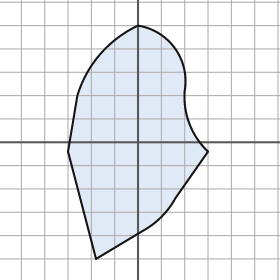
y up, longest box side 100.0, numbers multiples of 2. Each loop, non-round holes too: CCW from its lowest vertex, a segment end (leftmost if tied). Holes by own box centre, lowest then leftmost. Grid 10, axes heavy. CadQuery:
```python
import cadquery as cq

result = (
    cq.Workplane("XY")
    .moveTo(-18.0, -50.0)
    .lineTo(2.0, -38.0)
    .threePointArc((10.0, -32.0), (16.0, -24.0))
    .lineTo(30.0, -4.0)
    .threePointArc((22.0, 8.0), (20.0, 22.0))
    .threePointArc((16.0, 40.0), (0.0, 50.0))
    .threePointArc((-16.0, 38.0), (-26.0, 20.0))
    .lineTo(-30.0, -4.0)
    .close()
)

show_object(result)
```